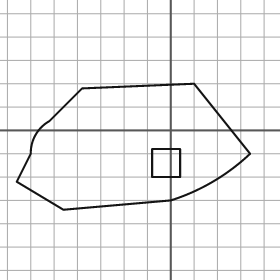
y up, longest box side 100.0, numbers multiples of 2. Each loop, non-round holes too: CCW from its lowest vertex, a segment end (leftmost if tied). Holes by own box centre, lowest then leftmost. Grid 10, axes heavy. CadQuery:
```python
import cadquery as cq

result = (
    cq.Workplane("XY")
    .moveTo(-46.0, -34.0)
    .lineTo(0.0, -30.0)
    .threePointArc((18.0, -22.0), (34.0, -10.0))
    .lineTo(10.0, 20.0)
    .lineTo(-38.0, 18.0)
    .lineTo(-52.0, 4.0)
    .threePointArc((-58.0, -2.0), (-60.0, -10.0))
    .lineTo(-66.0, -22.0)
    .close()
    .moveTo(-8.0, -20.0)
    .lineTo(4.0, -20.0)
    .lineTo(4.0, -8.0)
    .lineTo(-8.0, -8.0)
    .close()
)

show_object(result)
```